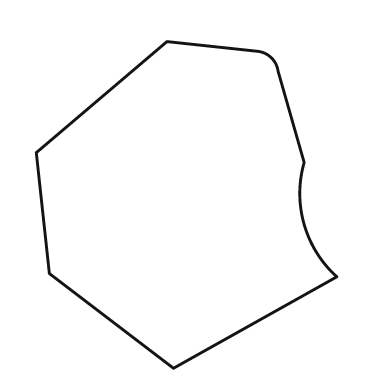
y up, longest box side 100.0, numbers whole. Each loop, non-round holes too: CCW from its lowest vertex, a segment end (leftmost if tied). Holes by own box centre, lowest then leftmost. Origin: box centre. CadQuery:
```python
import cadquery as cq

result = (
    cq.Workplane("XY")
    .moveTo(-4.0, -50.0)
    .lineTo(46.0, -22.0)
    .threePointArc((36.0, -6.0), (36.0, 13.0))
    .lineTo(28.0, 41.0)
    .threePointArc((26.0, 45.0), (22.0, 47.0))
    .lineTo(-6.0, 50.0)
    .lineTo(-46.0, 16.0)
    .lineTo(-42.0, -21.0)
    .close()
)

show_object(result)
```